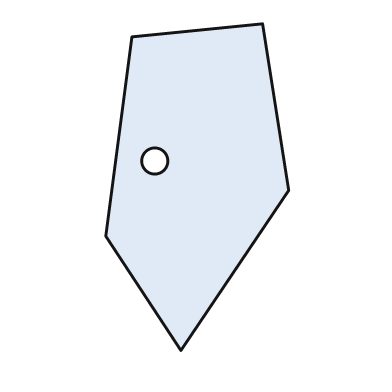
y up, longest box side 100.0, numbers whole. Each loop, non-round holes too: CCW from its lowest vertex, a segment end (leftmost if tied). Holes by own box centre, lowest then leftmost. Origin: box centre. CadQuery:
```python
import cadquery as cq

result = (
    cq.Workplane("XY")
    .moveTo(-5.0, -50.0)
    .lineTo(28.0, -1.0)
    .lineTo(20.0, 50.0)
    .lineTo(-20.0, 46.0)
    .lineTo(-28.0, -15.0)
    .close()
    .moveTo(-13.0, 8.0)
    .circle(4.0)
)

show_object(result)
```